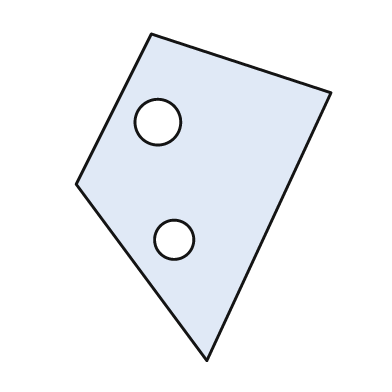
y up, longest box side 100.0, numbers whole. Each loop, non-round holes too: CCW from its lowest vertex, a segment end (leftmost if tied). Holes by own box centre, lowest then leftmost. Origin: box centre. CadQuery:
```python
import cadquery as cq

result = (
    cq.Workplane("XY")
    .moveTo(1.0, -50.0)
    .lineTo(39.0, 32.0)
    .lineTo(-16.0, 50.0)
    .lineTo(-39.0, 4.0)
    .close()
    .moveTo(-9.0, -13.0)
    .circle(6.0)
    .moveTo(-14.0, 23.0)
    .circle(7.0)
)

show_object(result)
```